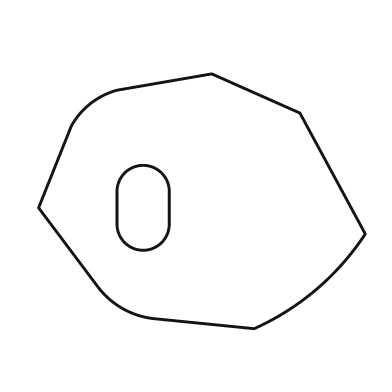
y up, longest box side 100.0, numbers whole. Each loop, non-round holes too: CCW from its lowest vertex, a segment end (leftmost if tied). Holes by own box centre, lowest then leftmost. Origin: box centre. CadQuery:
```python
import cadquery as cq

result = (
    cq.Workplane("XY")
    .moveTo(16.0, -39.0)
    .threePointArc((35.0, -27.0), (50.0, -10.0))
    .lineTo(30.0, 27.0)
    .lineTo(3.0, 39.0)
    .lineTo(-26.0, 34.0)
    .threePointArc((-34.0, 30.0), (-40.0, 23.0))
    .lineTo(-50.0, -2.0)
    .lineTo(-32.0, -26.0)
    .threePointArc((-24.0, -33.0), (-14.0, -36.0))
    .close()
    .moveTo(-26.0, -7.0)
    .threePointArc((-18.0, -15.0), (-10.0, -7.0))
    .lineTo(-10.0, 3.0)
    .threePointArc((-18.0, 11.0), (-26.0, 3.0))
    .close()
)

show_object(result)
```